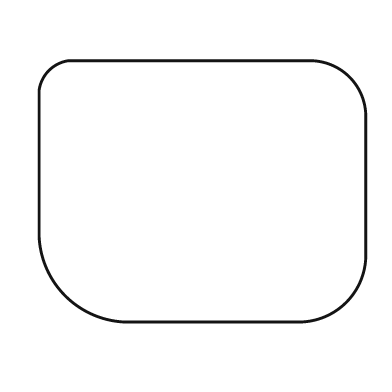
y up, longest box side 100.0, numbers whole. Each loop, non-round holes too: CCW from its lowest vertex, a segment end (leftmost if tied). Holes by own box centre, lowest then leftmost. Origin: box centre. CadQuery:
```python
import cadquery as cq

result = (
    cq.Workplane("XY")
    .moveTo(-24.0, -40.0)
    .lineTo(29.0, -40.0)
    .threePointArc((44.0, -34.0), (50.0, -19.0))
    .lineTo(50.0, 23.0)
    .threePointArc((45.0, 35.0), (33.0, 40.0))
    .lineTo(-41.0, 40.0)
    .threePointArc((-47.0, 37.0), (-50.0, 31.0))
    .lineTo(-50.0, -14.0)
    .threePointArc((-42.0, -32.0), (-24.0, -40.0))
    .close()
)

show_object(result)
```